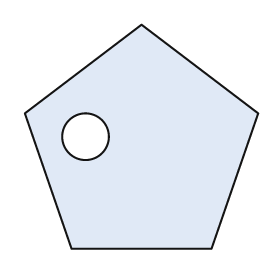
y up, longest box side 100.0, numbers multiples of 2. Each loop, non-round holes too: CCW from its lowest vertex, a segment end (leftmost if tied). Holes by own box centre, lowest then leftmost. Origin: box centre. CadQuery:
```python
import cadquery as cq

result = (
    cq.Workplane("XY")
    .moveTo(-30.0, -48.0)
    .lineTo(30.0, -48.0)
    .lineTo(50.0, 10.0)
    .lineTo(0.0, 48.0)
    .lineTo(-50.0, 10.0)
    .close()
    .moveTo(-24.0, 0.0)
    .circle(10.0)
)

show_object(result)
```